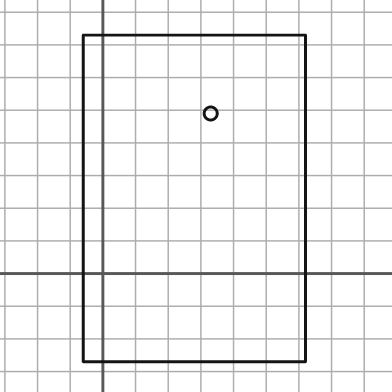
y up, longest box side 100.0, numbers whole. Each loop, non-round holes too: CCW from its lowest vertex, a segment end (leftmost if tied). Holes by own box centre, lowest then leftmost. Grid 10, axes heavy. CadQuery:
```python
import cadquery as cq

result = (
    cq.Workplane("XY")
    .moveTo(-6.0, -27.0)
    .lineTo(62.0, -27.0)
    .lineTo(62.0, 73.0)
    .lineTo(-6.0, 73.0)
    .close()
    .moveTo(33.0, 49.0)
    .circle(2.0)
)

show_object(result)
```